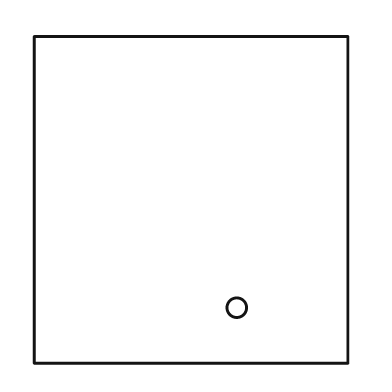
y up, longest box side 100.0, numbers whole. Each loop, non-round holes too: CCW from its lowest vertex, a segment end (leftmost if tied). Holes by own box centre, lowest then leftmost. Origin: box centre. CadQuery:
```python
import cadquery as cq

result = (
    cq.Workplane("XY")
    .moveTo(-48.0, -50.0)
    .lineTo(48.0, -50.0)
    .lineTo(48.0, 50.0)
    .lineTo(-48.0, 50.0)
    .close()
    .moveTo(14.0, -33.0)
    .circle(3.0)
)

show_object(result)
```